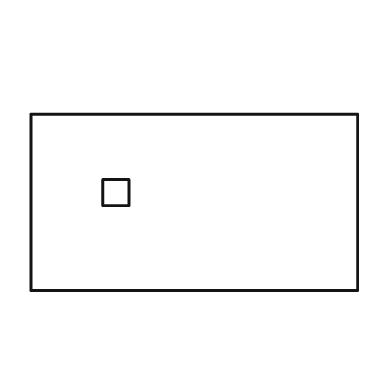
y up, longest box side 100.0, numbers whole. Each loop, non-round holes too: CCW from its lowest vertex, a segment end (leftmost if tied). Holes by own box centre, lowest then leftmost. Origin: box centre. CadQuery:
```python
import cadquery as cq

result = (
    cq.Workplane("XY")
    .moveTo(-50.0, -27.0)
    .lineTo(50.0, -27.0)
    .lineTo(50.0, 27.0)
    .lineTo(-50.0, 27.0)
    .close()
    .moveTo(-28.0, -1.0)
    .lineTo(-20.0, -1.0)
    .lineTo(-20.0, 7.0)
    .lineTo(-28.0, 7.0)
    .close()
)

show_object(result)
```